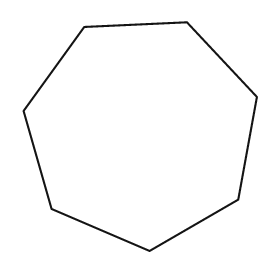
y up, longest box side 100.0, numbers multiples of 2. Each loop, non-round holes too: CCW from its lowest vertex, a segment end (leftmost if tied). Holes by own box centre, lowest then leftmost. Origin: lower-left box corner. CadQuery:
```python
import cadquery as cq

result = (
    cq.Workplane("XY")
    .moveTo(54.0, 0.0)
    .lineTo(92.0, 22.0)
    .lineTo(100.0, 66.0)
    .lineTo(70.0, 98.0)
    .lineTo(26.0, 96.0)
    .lineTo(0.0, 60.0)
    .lineTo(12.0, 18.0)
    .close()
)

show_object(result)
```